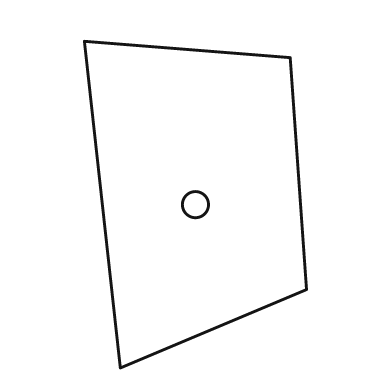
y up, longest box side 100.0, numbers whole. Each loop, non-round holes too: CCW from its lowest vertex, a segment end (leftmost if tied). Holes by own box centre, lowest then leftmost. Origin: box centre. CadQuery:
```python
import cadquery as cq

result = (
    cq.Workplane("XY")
    .moveTo(-23.0, -50.0)
    .lineTo(34.0, -26.0)
    .lineTo(29.0, 45.0)
    .lineTo(-34.0, 50.0)
    .close()
    .moveTo(0.0, 0.0)
    .circle(4.0)
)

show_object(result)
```